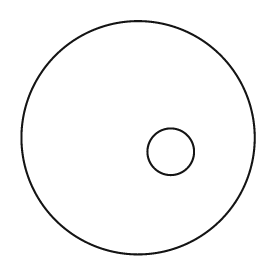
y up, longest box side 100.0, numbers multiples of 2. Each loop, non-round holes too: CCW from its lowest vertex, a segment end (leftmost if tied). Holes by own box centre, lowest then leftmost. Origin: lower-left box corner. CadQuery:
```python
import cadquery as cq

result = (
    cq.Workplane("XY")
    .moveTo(50.0, 50.0)
    .circle(50.0)
    .moveTo(64.0, 44.0)
    .circle(10.0)
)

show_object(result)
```